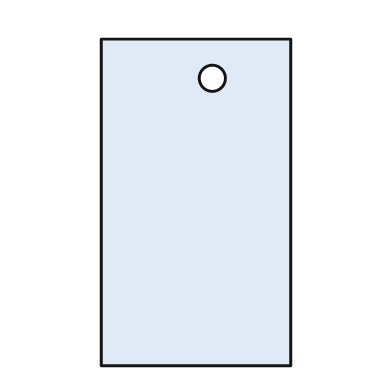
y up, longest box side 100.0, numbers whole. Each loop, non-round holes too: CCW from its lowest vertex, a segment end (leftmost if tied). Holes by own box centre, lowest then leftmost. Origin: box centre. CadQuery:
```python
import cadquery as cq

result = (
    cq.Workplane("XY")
    .moveTo(-29.0, -50.0)
    .lineTo(29.0, -50.0)
    .lineTo(29.0, 50.0)
    .lineTo(-29.0, 50.0)
    .close()
    .moveTo(5.0, 38.0)
    .circle(4.0)
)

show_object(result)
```